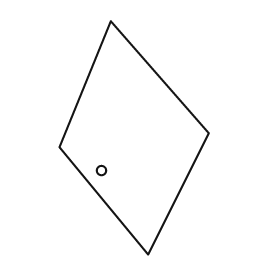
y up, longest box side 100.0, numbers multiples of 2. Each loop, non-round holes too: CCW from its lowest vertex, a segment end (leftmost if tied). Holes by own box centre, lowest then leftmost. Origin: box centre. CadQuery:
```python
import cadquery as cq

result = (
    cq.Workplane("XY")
    .moveTo(6.0, -50.0)
    .lineTo(32.0, 2.0)
    .lineTo(-10.0, 50.0)
    .lineTo(-32.0, -4.0)
    .close()
    .moveTo(-14.0, -14.0)
    .circle(2.0)
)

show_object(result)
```